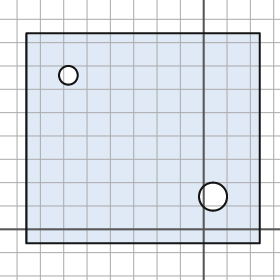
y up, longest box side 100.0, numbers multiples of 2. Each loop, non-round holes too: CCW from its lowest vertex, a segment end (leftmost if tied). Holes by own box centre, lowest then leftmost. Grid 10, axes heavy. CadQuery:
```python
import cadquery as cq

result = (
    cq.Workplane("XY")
    .moveTo(-76.0, -6.0)
    .lineTo(24.0, -6.0)
    .lineTo(24.0, 84.0)
    .lineTo(-76.0, 84.0)
    .close()
    .moveTo(4.0, 14.0)
    .circle(6.0)
    .moveTo(-58.0, 66.0)
    .circle(4.0)
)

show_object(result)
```